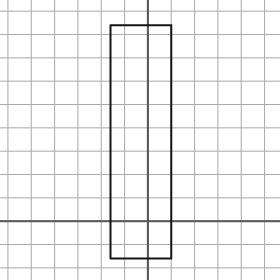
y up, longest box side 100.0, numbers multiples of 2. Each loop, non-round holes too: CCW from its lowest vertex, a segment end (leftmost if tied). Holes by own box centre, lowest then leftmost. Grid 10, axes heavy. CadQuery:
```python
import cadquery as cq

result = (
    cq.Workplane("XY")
    .moveTo(-16.0, -16.0)
    .lineTo(10.0, -16.0)
    .lineTo(10.0, 84.0)
    .lineTo(-16.0, 84.0)
    .close()
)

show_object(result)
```